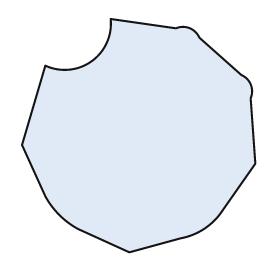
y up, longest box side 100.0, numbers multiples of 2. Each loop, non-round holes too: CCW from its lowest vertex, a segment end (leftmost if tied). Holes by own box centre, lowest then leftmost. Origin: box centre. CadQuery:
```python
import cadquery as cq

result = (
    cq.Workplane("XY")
    .moveTo(-4.0, -50.0)
    .lineTo(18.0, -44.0)
    .threePointArc((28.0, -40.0), (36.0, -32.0))
    .lineTo(50.0, -12.0)
    .lineTo(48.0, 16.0)
    .threePointArc((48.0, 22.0), (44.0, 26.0))
    .lineTo(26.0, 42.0)
    .threePointArc((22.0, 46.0), (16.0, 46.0))
    .lineTo(-12.0, 50.0)
    .threePointArc((-20.0, 32.0), (-40.0, 30.0))
    .lineTo(-50.0, -4.0)
    .lineTo(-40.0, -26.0)
    .threePointArc((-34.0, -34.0), (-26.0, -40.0))
    .close()
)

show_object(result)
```